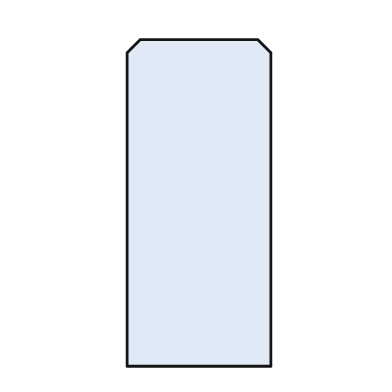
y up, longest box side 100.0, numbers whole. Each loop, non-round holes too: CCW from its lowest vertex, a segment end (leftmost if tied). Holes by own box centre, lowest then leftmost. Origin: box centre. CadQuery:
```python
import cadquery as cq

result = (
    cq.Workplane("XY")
    .moveTo(-22.0, -50.0)
    .lineTo(22.0, -50.0)
    .lineTo(22.0, 46.0)
    .lineTo(18.0, 50.0)
    .lineTo(-18.0, 50.0)
    .lineTo(-22.0, 46.0)
    .close()
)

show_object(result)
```